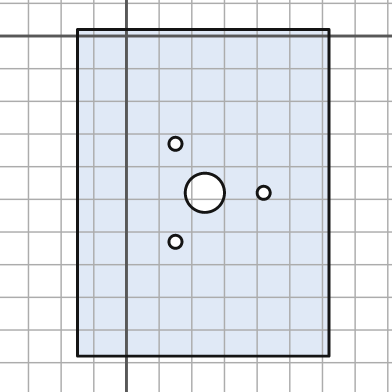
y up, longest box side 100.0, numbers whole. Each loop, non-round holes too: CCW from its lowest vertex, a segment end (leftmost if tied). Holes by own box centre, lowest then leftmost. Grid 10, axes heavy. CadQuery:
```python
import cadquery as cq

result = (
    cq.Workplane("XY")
    .moveTo(-15.0, -98.0)
    .lineTo(62.0, -98.0)
    .lineTo(62.0, 2.0)
    .lineTo(-15.0, 2.0)
    .close()
    .moveTo(15.0, -63.0)
    .circle(2.0)
    .moveTo(24.0, -48.0)
    .circle(6.0)
    .moveTo(42.0, -48.0)
    .circle(2.0)
    .moveTo(15.0, -33.0)
    .circle(2.0)
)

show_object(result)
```